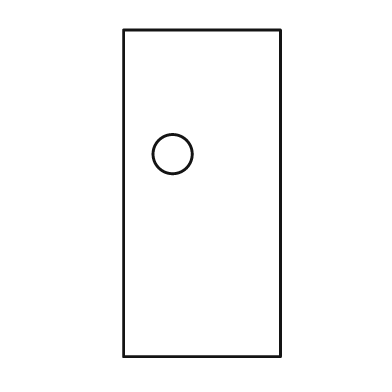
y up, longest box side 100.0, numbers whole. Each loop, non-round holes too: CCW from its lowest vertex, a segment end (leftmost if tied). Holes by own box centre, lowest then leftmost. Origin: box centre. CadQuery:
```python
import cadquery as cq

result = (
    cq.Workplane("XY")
    .moveTo(-24.0, -50.0)
    .lineTo(24.0, -50.0)
    .lineTo(24.0, 50.0)
    .lineTo(-24.0, 50.0)
    .close()
    .moveTo(-9.0, 12.0)
    .circle(6.0)
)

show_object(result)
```